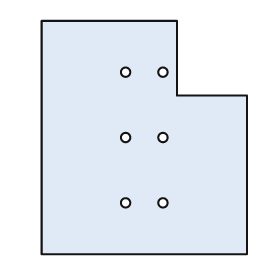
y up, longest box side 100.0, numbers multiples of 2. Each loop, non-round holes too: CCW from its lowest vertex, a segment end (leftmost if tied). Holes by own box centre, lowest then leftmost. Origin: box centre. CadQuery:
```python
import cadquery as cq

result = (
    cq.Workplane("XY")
    .moveTo(-44.0, -50.0)
    .lineTo(44.0, -50.0)
    .lineTo(44.0, 18.0)
    .lineTo(14.0, 18.0)
    .lineTo(14.0, 50.0)
    .lineTo(-44.0, 50.0)
    .close()
    .moveTo(-8.0, -28.0)
    .circle(2.0)
    .moveTo(8.0, -28.0)
    .circle(2.0)
    .moveTo(-8.0, 0.0)
    .circle(2.0)
    .moveTo(8.0, 0.0)
    .circle(2.0)
    .moveTo(-8.0, 28.0)
    .circle(2.0)
    .moveTo(8.0, 28.0)
    .circle(2.0)
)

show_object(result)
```